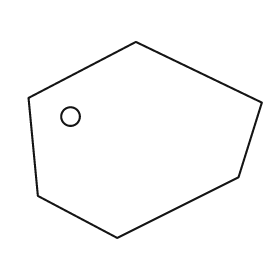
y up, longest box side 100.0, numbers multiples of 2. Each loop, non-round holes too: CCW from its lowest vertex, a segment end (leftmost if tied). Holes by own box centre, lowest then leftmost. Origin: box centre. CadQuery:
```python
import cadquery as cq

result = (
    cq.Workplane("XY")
    .moveTo(-12.0, -42.0)
    .lineTo(40.0, -16.0)
    .lineTo(50.0, 16.0)
    .lineTo(-4.0, 42.0)
    .lineTo(-50.0, 18.0)
    .lineTo(-46.0, -24.0)
    .close()
    .moveTo(-32.0, 10.0)
    .circle(4.0)
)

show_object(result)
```